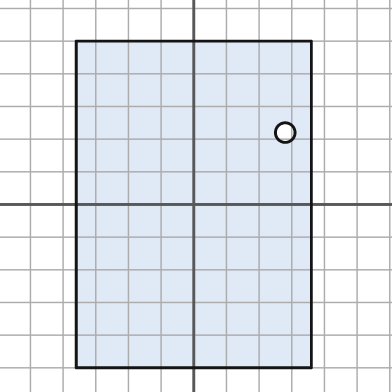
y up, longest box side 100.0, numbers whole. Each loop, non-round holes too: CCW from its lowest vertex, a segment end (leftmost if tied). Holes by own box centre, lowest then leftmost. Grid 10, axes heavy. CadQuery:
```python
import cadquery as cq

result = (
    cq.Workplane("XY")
    .moveTo(-36.0, -50.0)
    .lineTo(36.0, -50.0)
    .lineTo(36.0, 50.0)
    .lineTo(-36.0, 50.0)
    .close()
    .moveTo(28.0, 22.0)
    .circle(3.0)
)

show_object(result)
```